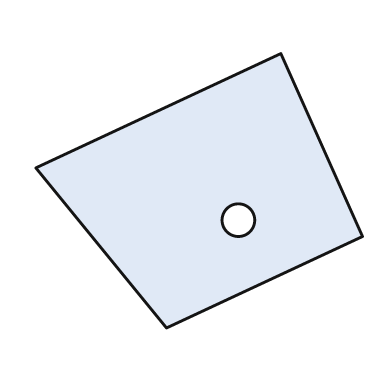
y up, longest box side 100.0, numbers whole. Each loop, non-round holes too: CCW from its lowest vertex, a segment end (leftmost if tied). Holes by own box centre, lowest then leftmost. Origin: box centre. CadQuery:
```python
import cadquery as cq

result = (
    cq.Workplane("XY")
    .moveTo(-10.0, -42.0)
    .lineTo(50.0, -14.0)
    .lineTo(25.0, 42.0)
    .lineTo(-50.0, 7.0)
    .close()
    .moveTo(12.0, -9.0)
    .circle(5.0)
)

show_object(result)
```